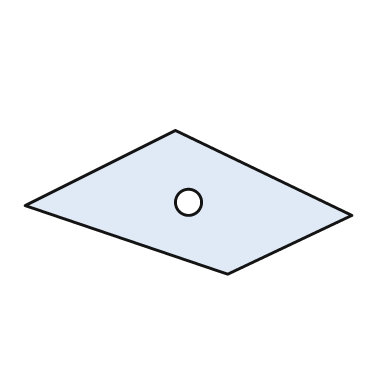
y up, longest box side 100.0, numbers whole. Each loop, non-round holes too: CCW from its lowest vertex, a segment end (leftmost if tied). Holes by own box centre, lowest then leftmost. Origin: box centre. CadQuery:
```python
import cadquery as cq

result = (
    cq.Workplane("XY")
    .moveTo(12.0, -22.0)
    .lineTo(50.0, -4.0)
    .lineTo(-4.0, 22.0)
    .lineTo(-50.0, -1.0)
    .close()
    .moveTo(0.0, 0.0)
    .circle(4.0)
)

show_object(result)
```